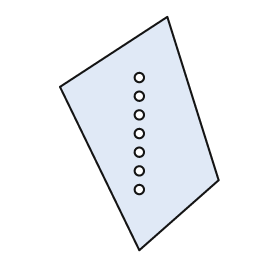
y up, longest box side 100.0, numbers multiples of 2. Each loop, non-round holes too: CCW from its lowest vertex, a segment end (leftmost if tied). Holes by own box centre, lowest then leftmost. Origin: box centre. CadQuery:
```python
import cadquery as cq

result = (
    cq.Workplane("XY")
    .moveTo(0.0, -50.0)
    .lineTo(34.0, -20.0)
    .lineTo(12.0, 50.0)
    .lineTo(-34.0, 20.0)
    .close()
    .moveTo(0.0, -24.0)
    .circle(2.0)
    .moveTo(0.0, -16.0)
    .circle(2.0)
    .moveTo(0.0, -8.0)
    .circle(2.0)
    .moveTo(0.0, 0.0)
    .circle(2.0)
    .moveTo(0.0, 8.0)
    .circle(2.0)
    .moveTo(0.0, 16.0)
    .circle(2.0)
    .moveTo(0.0, 24.0)
    .circle(2.0)
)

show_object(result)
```